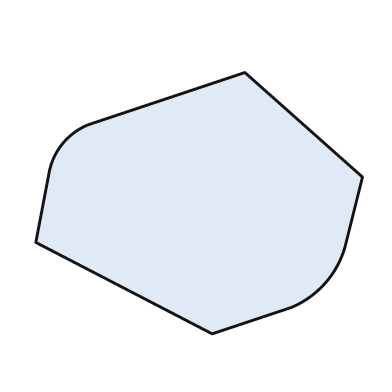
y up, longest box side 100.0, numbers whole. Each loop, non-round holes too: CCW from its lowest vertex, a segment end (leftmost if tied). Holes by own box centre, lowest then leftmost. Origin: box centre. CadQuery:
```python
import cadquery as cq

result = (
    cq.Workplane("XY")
    .moveTo(4.0, -40.0)
    .lineTo(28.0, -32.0)
    .threePointArc((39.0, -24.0), (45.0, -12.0))
    .lineTo(50.0, 8.0)
    .lineTo(14.0, 40.0)
    .lineTo(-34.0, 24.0)
    .threePointArc((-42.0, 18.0), (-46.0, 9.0))
    .lineTo(-50.0, -12.0)
    .close()
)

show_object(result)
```